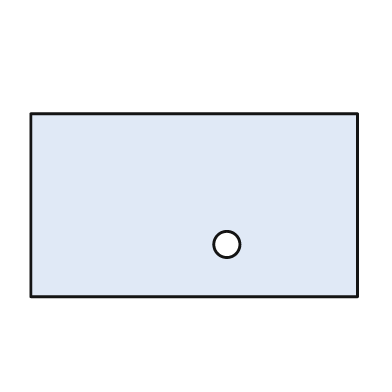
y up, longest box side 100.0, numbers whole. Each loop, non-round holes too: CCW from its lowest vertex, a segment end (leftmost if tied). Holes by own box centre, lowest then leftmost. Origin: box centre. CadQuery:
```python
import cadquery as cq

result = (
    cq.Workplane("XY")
    .moveTo(-50.0, -28.0)
    .lineTo(50.0, -28.0)
    .lineTo(50.0, 28.0)
    .lineTo(-50.0, 28.0)
    .close()
    .moveTo(10.0, -12.0)
    .circle(4.0)
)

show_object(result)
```